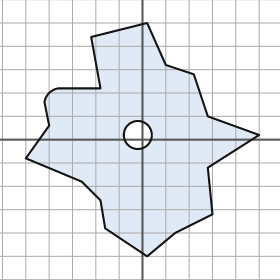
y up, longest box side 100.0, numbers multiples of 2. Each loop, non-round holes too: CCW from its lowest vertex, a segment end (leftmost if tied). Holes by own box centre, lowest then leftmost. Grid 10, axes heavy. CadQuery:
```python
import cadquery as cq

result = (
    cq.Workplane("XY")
    .moveTo(2.0, -50.0)
    .lineTo(14.0, -40.0)
    .lineTo(30.0, -32.0)
    .lineTo(28.0, -12.0)
    .lineTo(50.0, 2.0)
    .lineTo(28.0, 10.0)
    .lineTo(22.0, 28.0)
    .lineTo(10.0, 32.0)
    .lineTo(2.0, 50.0)
    .lineTo(-22.0, 44.0)
    .lineTo(-18.0, 22.0)
    .lineTo(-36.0, 22.0)
    .threePointArc((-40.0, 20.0), (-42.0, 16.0))
    .lineTo(-40.0, 6.0)
    .lineTo(-50.0, -8.0)
    .lineTo(-26.0, -18.0)
    .lineTo(-18.0, -26.0)
    .lineTo(-16.0, -38.0)
    .close()
    .moveTo(-2.0, 2.0)
    .circle(6.0)
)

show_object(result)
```